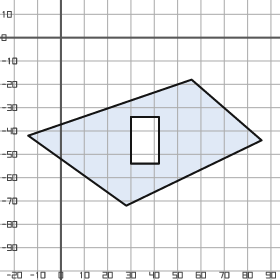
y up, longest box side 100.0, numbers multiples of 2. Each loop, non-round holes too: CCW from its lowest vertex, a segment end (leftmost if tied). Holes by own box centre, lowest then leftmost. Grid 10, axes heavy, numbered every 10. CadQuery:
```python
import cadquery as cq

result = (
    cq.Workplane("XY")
    .moveTo(28.0, -72.0)
    .lineTo(86.0, -44.0)
    .lineTo(56.0, -18.0)
    .lineTo(-14.0, -42.0)
    .close()
    .moveTo(30.0, -54.0)
    .lineTo(42.0, -54.0)
    .lineTo(42.0, -34.0)
    .lineTo(30.0, -34.0)
    .close()
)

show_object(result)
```